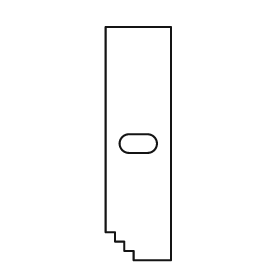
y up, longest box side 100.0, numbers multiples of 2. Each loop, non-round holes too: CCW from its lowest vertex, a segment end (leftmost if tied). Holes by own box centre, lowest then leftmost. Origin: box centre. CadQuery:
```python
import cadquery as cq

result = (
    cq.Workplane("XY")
    .moveTo(-2.0, -50.0)
    .lineTo(14.0, -50.0)
    .lineTo(14.0, 50.0)
    .lineTo(-14.0, 50.0)
    .lineTo(-14.0, -38.0)
    .lineTo(-10.0, -38.0)
    .lineTo(-10.0, -42.0)
    .lineTo(-6.0, -42.0)
    .lineTo(-6.0, -46.0)
    .lineTo(-2.0, -46.0)
    .close()
    .moveTo(-4.0, -4.0)
    .lineTo(4.0, -4.0)
    .threePointArc((8.0, 0.0), (4.0, 4.0))
    .lineTo(-4.0, 4.0)
    .threePointArc((-8.0, 0.0), (-4.0, -4.0))
    .close()
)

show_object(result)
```